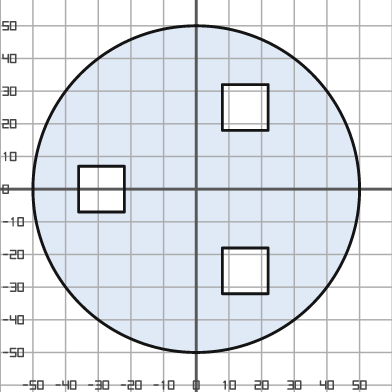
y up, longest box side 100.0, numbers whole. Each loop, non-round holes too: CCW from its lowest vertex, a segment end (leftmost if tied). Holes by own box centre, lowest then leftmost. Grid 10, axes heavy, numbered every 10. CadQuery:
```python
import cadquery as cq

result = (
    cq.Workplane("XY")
    .moveTo(0.0, 0.0)
    .circle(50.0)
    .moveTo(8.0, -32.0)
    .lineTo(22.0, -32.0)
    .lineTo(22.0, -18.0)
    .lineTo(8.0, -18.0)
    .close()
    .moveTo(-36.0, -7.0)
    .lineTo(-22.0, -7.0)
    .lineTo(-22.0, 7.0)
    .lineTo(-36.0, 7.0)
    .close()
    .moveTo(8.0, 18.0)
    .lineTo(22.0, 18.0)
    .lineTo(22.0, 32.0)
    .lineTo(8.0, 32.0)
    .close()
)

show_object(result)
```